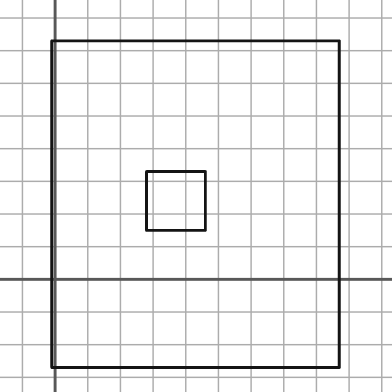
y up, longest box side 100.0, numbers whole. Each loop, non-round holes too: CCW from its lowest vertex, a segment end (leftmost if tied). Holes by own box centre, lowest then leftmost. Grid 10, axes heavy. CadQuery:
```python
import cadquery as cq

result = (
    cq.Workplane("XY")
    .moveTo(-1.0, -27.0)
    .lineTo(87.0, -27.0)
    .lineTo(87.0, 73.0)
    .lineTo(-1.0, 73.0)
    .close()
    .moveTo(28.0, 15.0)
    .lineTo(46.0, 15.0)
    .lineTo(46.0, 33.0)
    .lineTo(28.0, 33.0)
    .close()
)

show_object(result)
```